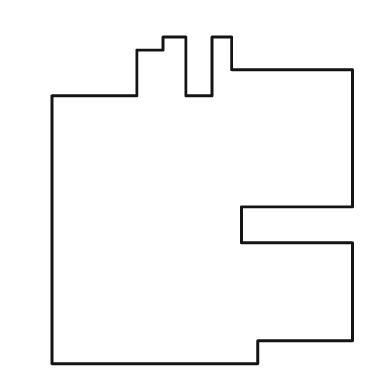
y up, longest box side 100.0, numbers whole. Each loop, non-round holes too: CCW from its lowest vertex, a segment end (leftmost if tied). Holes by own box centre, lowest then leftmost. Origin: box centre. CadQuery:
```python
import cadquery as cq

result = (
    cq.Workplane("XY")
    .moveTo(-46.0, -50.0)
    .lineTo(17.0, -50.0)
    .lineTo(17.0, -43.0)
    .lineTo(46.0, -43.0)
    .lineTo(46.0, -13.0)
    .lineTo(12.0, -13.0)
    .lineTo(12.0, -2.0)
    .lineTo(46.0, -2.0)
    .lineTo(46.0, 40.0)
    .lineTo(9.0, 40.0)
    .lineTo(9.0, 50.0)
    .lineTo(3.0, 50.0)
    .lineTo(3.0, 32.0)
    .lineTo(-5.0, 32.0)
    .lineTo(-5.0, 50.0)
    .lineTo(-12.0, 50.0)
    .lineTo(-12.0, 46.0)
    .lineTo(-20.0, 46.0)
    .lineTo(-20.0, 32.0)
    .lineTo(-46.0, 32.0)
    .close()
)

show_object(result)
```